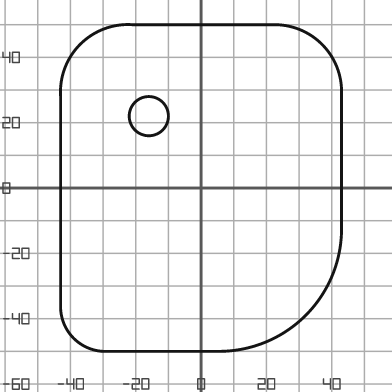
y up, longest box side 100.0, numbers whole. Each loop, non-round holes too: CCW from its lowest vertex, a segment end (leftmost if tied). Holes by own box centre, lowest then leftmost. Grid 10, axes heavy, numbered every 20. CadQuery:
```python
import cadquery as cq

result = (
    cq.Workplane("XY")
    .moveTo(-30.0, -50.0)
    .lineTo(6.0, -50.0)
    .threePointArc((32.0, -39.0), (43.0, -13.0))
    .lineTo(43.0, 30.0)
    .threePointArc((37.0, 44.0), (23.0, 50.0))
    .lineTo(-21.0, 50.0)
    .threePointArc((-37.0, 44.0), (-43.0, 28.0))
    .lineTo(-43.0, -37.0)
    .threePointArc((-39.0, -46.0), (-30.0, -50.0))
    .close()
    .moveTo(-16.0, 22.0)
    .circle(6.0)
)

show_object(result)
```